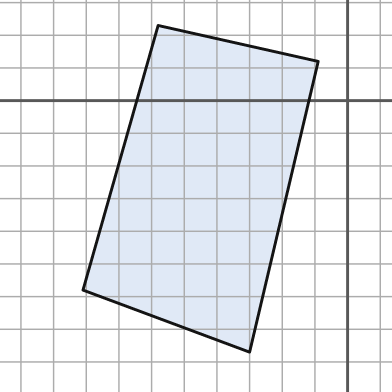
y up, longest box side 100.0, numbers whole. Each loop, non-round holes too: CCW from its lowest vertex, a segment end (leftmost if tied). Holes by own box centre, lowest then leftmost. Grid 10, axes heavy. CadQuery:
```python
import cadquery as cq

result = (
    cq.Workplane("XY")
    .moveTo(-30.0, -77.0)
    .lineTo(-9.0, 12.0)
    .lineTo(-58.0, 23.0)
    .lineTo(-81.0, -58.0)
    .close()
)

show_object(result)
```